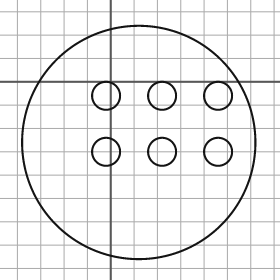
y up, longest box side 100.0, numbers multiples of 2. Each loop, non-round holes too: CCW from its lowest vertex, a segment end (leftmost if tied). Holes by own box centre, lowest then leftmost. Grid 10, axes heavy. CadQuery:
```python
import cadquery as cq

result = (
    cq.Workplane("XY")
    .moveTo(12.0, -26.0)
    .circle(50.0)
    .moveTo(-2.0, -30.0)
    .circle(6.0)
    .moveTo(22.0, -30.0)
    .circle(6.0)
    .moveTo(46.0, -30.0)
    .circle(6.0)
    .moveTo(-2.0, -6.0)
    .circle(6.0)
    .moveTo(22.0, -6.0)
    .circle(6.0)
    .moveTo(46.0, -6.0)
    .circle(6.0)
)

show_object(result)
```